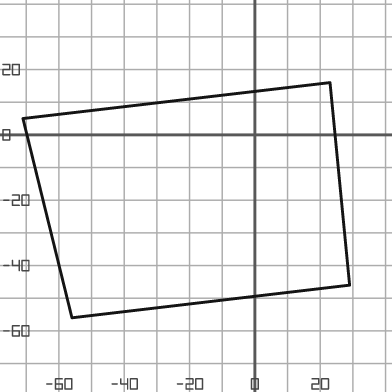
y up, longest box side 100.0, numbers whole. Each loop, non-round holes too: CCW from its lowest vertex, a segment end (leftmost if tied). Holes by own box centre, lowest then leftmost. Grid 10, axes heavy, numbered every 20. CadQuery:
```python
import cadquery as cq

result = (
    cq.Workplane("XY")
    .moveTo(-56.0, -56.0)
    .lineTo(29.0, -46.0)
    .lineTo(23.0, 16.0)
    .lineTo(-71.0, 5.0)
    .close()
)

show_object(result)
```